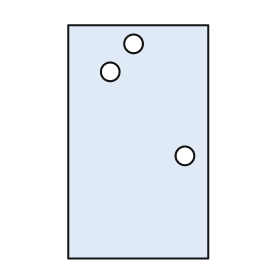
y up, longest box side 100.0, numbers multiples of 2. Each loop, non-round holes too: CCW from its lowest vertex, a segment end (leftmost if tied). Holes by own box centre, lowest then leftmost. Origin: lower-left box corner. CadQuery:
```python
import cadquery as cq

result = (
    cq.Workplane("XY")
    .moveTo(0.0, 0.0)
    .lineTo(60.0, 0.0)
    .lineTo(60.0, 100.0)
    .lineTo(0.0, 100.0)
    .close()
    .moveTo(50.0, 44.0)
    .circle(4.0)
    .moveTo(18.0, 80.0)
    .circle(4.0)
    .moveTo(28.0, 92.0)
    .circle(4.0)
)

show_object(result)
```